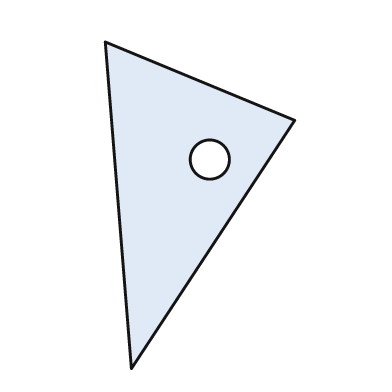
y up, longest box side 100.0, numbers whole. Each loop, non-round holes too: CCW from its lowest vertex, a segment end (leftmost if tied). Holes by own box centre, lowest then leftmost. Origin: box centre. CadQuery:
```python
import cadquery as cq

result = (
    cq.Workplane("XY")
    .moveTo(-21.0, -50.0)
    .lineTo(29.0, 26.0)
    .lineTo(-29.0, 50.0)
    .close()
    .moveTo(3.0, 14.0)
    .circle(6.0)
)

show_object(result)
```